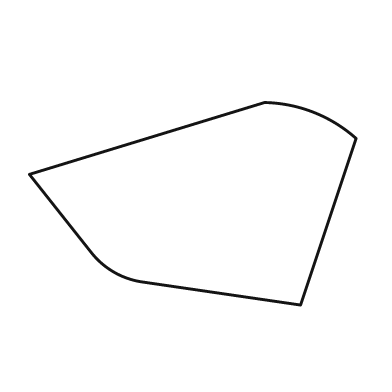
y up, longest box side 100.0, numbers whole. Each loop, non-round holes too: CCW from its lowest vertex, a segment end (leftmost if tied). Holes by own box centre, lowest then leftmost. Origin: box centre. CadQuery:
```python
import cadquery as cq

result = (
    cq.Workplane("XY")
    .moveTo(33.0, -31.0)
    .lineTo(50.0, 20.0)
    .threePointArc((37.0, 28.0), (22.0, 31.0))
    .lineTo(-50.0, 9.0)
    .lineTo(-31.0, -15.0)
    .threePointArc((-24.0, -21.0), (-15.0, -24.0))
    .close()
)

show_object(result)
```